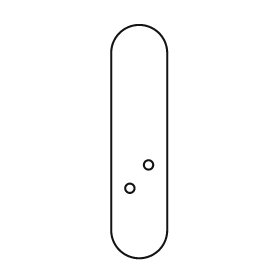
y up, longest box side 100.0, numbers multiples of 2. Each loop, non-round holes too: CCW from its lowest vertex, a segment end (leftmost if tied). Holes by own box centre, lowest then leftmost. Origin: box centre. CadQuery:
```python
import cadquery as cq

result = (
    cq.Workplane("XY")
    .moveTo(-12.0, -38.0)
    .threePointArc((0.0, -50.0), (12.0, -38.0))
    .lineTo(12.0, 38.0)
    .threePointArc((0.0, 50.0), (-12.0, 38.0))
    .close()
    .moveTo(-4.0, -20.0)
    .circle(2.0)
    .moveTo(4.0, -10.0)
    .circle(2.0)
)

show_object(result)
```